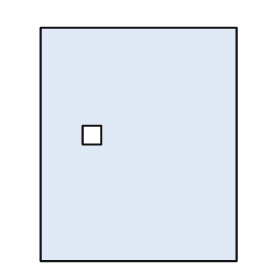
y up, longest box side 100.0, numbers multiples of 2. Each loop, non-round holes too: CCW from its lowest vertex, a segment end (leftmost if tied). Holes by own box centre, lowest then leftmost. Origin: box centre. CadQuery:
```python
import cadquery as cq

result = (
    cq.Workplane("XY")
    .moveTo(-42.0, -50.0)
    .lineTo(42.0, -50.0)
    .lineTo(42.0, 50.0)
    .lineTo(-42.0, 50.0)
    .close()
    .moveTo(-24.0, 0.0)
    .lineTo(-16.0, 0.0)
    .lineTo(-16.0, 8.0)
    .lineTo(-24.0, 8.0)
    .close()
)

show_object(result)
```